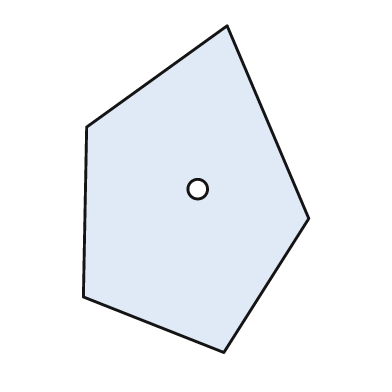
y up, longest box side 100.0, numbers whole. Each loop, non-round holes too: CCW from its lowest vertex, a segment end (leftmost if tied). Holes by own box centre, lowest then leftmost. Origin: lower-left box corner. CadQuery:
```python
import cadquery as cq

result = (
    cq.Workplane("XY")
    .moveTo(43.0, 0.0)
    .lineTo(69.0, 41.0)
    .lineTo(44.0, 100.0)
    .lineTo(1.0, 69.0)
    .lineTo(0.0, 17.0)
    .close()
    .moveTo(35.0, 50.0)
    .circle(3.0)
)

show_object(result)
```